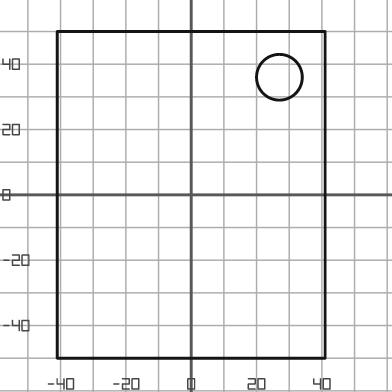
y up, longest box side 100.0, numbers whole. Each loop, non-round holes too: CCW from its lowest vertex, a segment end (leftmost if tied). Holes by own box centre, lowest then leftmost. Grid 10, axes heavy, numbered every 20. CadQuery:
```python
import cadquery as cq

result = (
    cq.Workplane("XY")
    .moveTo(-41.0, -50.0)
    .lineTo(41.0, -50.0)
    .lineTo(41.0, 50.0)
    .lineTo(-41.0, 50.0)
    .close()
    .moveTo(27.0, 36.0)
    .circle(7.0)
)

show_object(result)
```